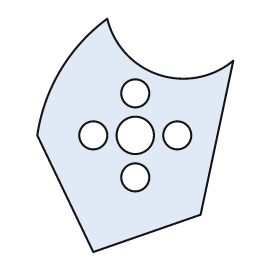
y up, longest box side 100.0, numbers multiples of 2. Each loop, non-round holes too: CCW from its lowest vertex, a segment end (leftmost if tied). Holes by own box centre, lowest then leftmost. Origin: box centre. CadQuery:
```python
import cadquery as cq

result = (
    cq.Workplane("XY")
    .moveTo(-18.0, -50.0)
    .lineTo(28.0, -34.0)
    .lineTo(42.0, 32.0)
    .threePointArc((10.0, 26.0), (-12.0, 50.0))
    .threePointArc((-32.0, 28.0), (-42.0, 0.0))
    .close()
    .moveTo(0.0, -18.0)
    .circle(6.0)
    .moveTo(-18.0, 0.0)
    .circle(6.0)
    .moveTo(0.0, 0.0)
    .circle(8.0)
    .moveTo(18.0, 0.0)
    .circle(6.0)
    .moveTo(0.0, 18.0)
    .circle(6.0)
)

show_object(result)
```